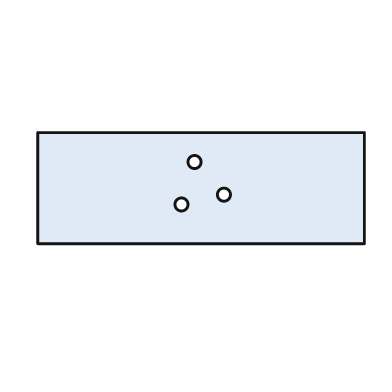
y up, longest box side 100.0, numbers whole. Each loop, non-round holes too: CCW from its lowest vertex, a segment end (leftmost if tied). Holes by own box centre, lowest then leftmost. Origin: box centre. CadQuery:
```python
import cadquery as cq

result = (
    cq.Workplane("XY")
    .moveTo(-50.0, -17.0)
    .lineTo(50.0, -17.0)
    .lineTo(50.0, 17.0)
    .lineTo(-50.0, 17.0)
    .close()
    .moveTo(-6.0, -5.0)
    .circle(2.0)
    .moveTo(7.0, -2.0)
    .circle(2.0)
    .moveTo(-2.0, 8.0)
    .circle(2.0)
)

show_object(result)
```